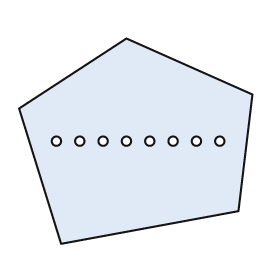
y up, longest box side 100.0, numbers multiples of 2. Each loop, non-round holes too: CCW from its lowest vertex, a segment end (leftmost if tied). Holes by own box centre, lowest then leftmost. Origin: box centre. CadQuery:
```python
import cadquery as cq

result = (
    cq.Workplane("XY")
    .moveTo(-32.0, -44.0)
    .lineTo(44.0, -30.0)
    .lineTo(50.0, 20.0)
    .lineTo(-4.0, 44.0)
    .lineTo(-50.0, 14.0)
    .close()
    .moveTo(-34.0, 0.0)
    .circle(2.0)
    .moveTo(-24.0, 0.0)
    .circle(2.0)
    .moveTo(-14.0, 0.0)
    .circle(2.0)
    .moveTo(-4.0, 0.0)
    .circle(2.0)
    .moveTo(6.0, 0.0)
    .circle(2.0)
    .moveTo(16.0, 0.0)
    .circle(2.0)
    .moveTo(26.0, 0.0)
    .circle(2.0)
    .moveTo(36.0, 0.0)
    .circle(2.0)
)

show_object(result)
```